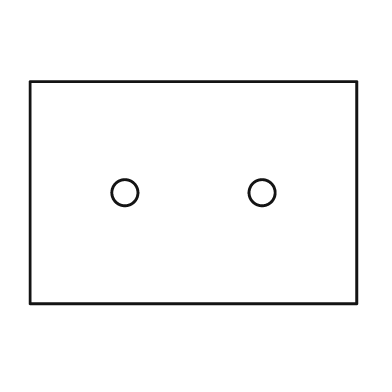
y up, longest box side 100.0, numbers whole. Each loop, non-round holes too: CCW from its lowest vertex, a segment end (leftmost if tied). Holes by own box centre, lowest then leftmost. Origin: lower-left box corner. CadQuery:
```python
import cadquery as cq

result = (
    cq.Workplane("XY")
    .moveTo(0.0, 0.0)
    .lineTo(100.0, 0.0)
    .lineTo(100.0, 68.0)
    .lineTo(0.0, 68.0)
    .close()
    .moveTo(29.0, 34.0)
    .circle(4.0)
    .moveTo(71.0, 34.0)
    .circle(4.0)
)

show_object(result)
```